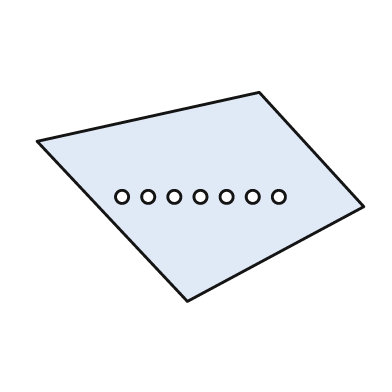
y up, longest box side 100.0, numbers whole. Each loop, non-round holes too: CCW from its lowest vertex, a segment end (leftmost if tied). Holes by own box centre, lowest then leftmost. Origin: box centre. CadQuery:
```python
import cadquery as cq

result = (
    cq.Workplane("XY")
    .moveTo(-4.0, -32.0)
    .lineTo(50.0, -3.0)
    .lineTo(18.0, 32.0)
    .lineTo(-50.0, 17.0)
    .close()
    .moveTo(-24.0, 0.0)
    .circle(2.0)
    .moveTo(-16.0, 0.0)
    .circle(2.0)
    .moveTo(-8.0, 0.0)
    .circle(2.0)
    .moveTo(0.0, 0.0)
    .circle(2.0)
    .moveTo(8.0, 0.0)
    .circle(2.0)
    .moveTo(16.0, 0.0)
    .circle(2.0)
    .moveTo(24.0, 0.0)
    .circle(2.0)
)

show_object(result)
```